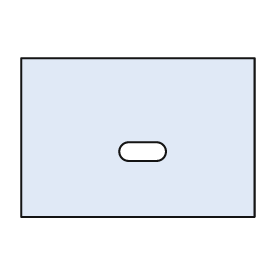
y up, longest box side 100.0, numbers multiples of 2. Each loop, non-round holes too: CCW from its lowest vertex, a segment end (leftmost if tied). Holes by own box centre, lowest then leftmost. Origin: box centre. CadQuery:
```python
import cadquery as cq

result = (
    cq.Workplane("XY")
    .moveTo(-50.0, -34.0)
    .lineTo(50.0, -34.0)
    .lineTo(50.0, 34.0)
    .lineTo(-50.0, 34.0)
    .close()
    .moveTo(-4.0, -10.0)
    .lineTo(8.0, -10.0)
    .threePointArc((12.0, -6.0), (8.0, -2.0))
    .lineTo(-4.0, -2.0)
    .threePointArc((-8.0, -6.0), (-4.0, -10.0))
    .close()
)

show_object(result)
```